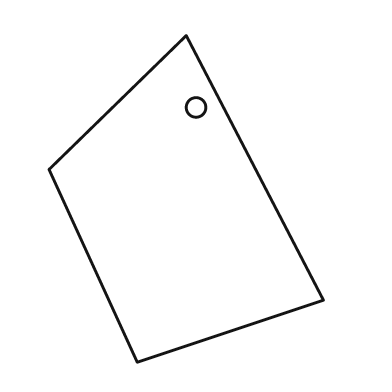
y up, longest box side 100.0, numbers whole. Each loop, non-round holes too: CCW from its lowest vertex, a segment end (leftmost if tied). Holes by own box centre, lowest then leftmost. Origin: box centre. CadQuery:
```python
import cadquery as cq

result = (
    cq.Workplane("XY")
    .moveTo(-15.0, -50.0)
    .lineTo(42.0, -31.0)
    .lineTo(0.0, 50.0)
    .lineTo(-42.0, 9.0)
    .close()
    .moveTo(3.0, 28.0)
    .circle(3.0)
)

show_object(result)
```